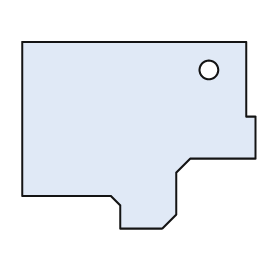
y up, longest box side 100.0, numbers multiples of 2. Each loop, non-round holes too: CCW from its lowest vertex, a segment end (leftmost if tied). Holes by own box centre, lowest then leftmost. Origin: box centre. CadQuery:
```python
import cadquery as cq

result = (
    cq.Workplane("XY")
    .moveTo(-8.0, -40.0)
    .lineTo(10.0, -40.0)
    .lineTo(16.0, -34.0)
    .lineTo(16.0, -16.0)
    .lineTo(22.0, -10.0)
    .lineTo(50.0, -10.0)
    .lineTo(50.0, 8.0)
    .lineTo(46.0, 8.0)
    .lineTo(46.0, 40.0)
    .lineTo(-50.0, 40.0)
    .lineTo(-50.0, -26.0)
    .lineTo(-12.0, -26.0)
    .lineTo(-8.0, -30.0)
    .close()
    .moveTo(30.0, 28.0)
    .circle(4.0)
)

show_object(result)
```